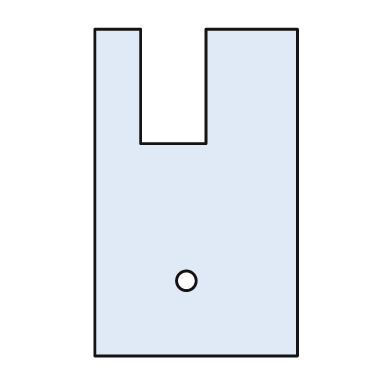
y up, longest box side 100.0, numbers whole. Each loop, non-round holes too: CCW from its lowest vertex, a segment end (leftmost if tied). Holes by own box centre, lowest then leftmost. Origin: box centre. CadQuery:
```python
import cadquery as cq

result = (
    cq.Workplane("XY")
    .moveTo(-31.0, -50.0)
    .lineTo(31.0, -50.0)
    .lineTo(31.0, 50.0)
    .lineTo(3.0, 50.0)
    .lineTo(3.0, 15.0)
    .lineTo(-17.0, 15.0)
    .lineTo(-17.0, 50.0)
    .lineTo(-31.0, 50.0)
    .close()
    .moveTo(-3.0, -27.0)
    .circle(3.0)
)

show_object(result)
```